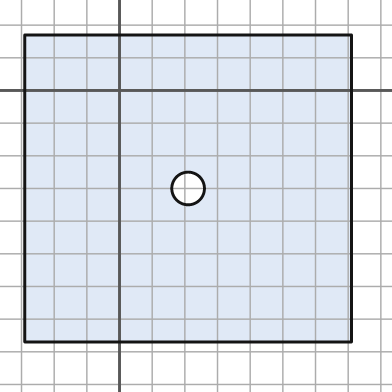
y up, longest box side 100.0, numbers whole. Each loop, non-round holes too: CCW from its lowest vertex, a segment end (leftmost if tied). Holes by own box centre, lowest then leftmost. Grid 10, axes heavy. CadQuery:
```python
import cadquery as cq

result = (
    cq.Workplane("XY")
    .moveTo(-29.0, -77.0)
    .lineTo(71.0, -77.0)
    .lineTo(71.0, 17.0)
    .lineTo(-29.0, 17.0)
    .close()
    .moveTo(21.0, -30.0)
    .circle(5.0)
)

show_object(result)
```